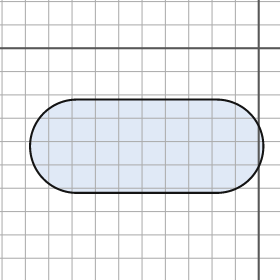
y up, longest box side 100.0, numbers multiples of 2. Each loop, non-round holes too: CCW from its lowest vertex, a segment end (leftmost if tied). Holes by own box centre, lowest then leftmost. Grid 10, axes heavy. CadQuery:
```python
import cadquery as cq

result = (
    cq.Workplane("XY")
    .moveTo(-78.0, -62.0)
    .lineTo(-18.0, -62.0)
    .threePointArc((2.0, -42.0), (-18.0, -22.0))
    .lineTo(-78.0, -22.0)
    .threePointArc((-98.0, -42.0), (-78.0, -62.0))
    .close()
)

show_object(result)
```